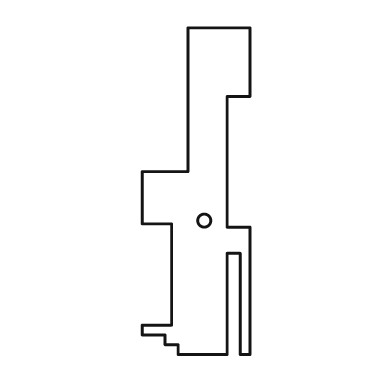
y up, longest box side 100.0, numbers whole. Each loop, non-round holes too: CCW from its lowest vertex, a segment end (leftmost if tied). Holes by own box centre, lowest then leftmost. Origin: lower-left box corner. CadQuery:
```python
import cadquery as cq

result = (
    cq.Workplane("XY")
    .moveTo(11.0, 0.0)
    .lineTo(26.0, 0.0)
    .lineTo(26.0, 31.0)
    .lineTo(30.0, 31.0)
    .lineTo(30.0, 0.0)
    .lineTo(33.0, 0.0)
    .lineTo(33.0, 39.0)
    .lineTo(26.0, 39.0)
    .lineTo(26.0, 79.0)
    .lineTo(33.0, 79.0)
    .lineTo(33.0, 100.0)
    .lineTo(14.0, 100.0)
    .lineTo(14.0, 56.0)
    .lineTo(0.0, 56.0)
    .lineTo(0.0, 40.0)
    .lineTo(9.0, 40.0)
    .lineTo(9.0, 9.0)
    .lineTo(0.0, 9.0)
    .lineTo(0.0, 6.0)
    .lineTo(7.0, 6.0)
    .lineTo(7.0, 3.0)
    .lineTo(11.0, 3.0)
    .close()
    .moveTo(19.0, 41.0)
    .circle(2.0)
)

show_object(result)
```